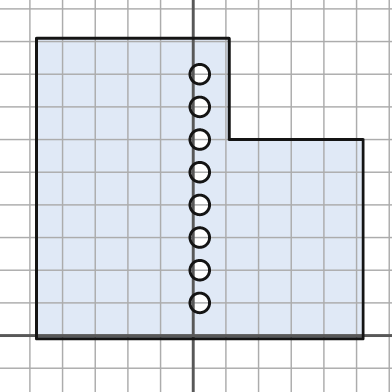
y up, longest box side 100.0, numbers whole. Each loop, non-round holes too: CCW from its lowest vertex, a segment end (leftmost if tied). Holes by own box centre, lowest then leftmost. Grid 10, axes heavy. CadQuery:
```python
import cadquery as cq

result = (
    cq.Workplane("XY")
    .moveTo(-48.0, -1.0)
    .lineTo(52.0, -1.0)
    .lineTo(52.0, 60.0)
    .lineTo(11.0, 60.0)
    .lineTo(11.0, 91.0)
    .lineTo(-48.0, 91.0)
    .close()
    .moveTo(2.0, 10.0)
    .circle(3.0)
    .moveTo(2.0, 20.0)
    .circle(3.0)
    .moveTo(2.0, 30.0)
    .circle(3.0)
    .moveTo(2.0, 40.0)
    .circle(3.0)
    .moveTo(2.0, 50.0)
    .circle(3.0)
    .moveTo(2.0, 60.0)
    .circle(3.0)
    .moveTo(2.0, 70.0)
    .circle(3.0)
    .moveTo(2.0, 80.0)
    .circle(3.0)
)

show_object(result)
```